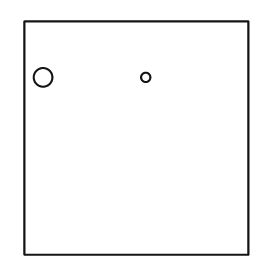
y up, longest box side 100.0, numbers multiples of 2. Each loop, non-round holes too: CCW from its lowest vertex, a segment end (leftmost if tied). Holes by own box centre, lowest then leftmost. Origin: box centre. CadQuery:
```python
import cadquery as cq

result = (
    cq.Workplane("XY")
    .moveTo(-48.0, -50.0)
    .lineTo(48.0, -50.0)
    .lineTo(48.0, 50.0)
    .lineTo(-48.0, 50.0)
    .close()
    .moveTo(-40.0, 26.0)
    .circle(4.0)
    .moveTo(4.0, 26.0)
    .circle(2.0)
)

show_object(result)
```